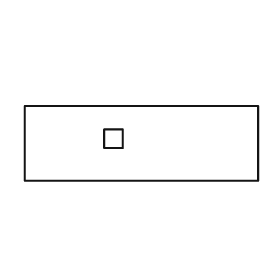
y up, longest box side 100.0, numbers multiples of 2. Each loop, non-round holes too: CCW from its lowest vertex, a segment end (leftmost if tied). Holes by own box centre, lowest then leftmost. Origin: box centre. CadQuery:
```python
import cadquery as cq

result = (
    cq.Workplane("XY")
    .moveTo(-50.0, -16.0)
    .lineTo(50.0, -16.0)
    .lineTo(50.0, 16.0)
    .lineTo(-50.0, 16.0)
    .close()
    .moveTo(-16.0, -2.0)
    .lineTo(-8.0, -2.0)
    .lineTo(-8.0, 6.0)
    .lineTo(-16.0, 6.0)
    .close()
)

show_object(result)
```